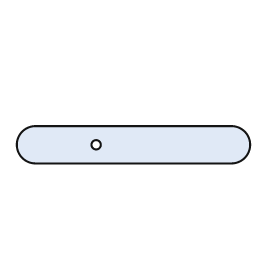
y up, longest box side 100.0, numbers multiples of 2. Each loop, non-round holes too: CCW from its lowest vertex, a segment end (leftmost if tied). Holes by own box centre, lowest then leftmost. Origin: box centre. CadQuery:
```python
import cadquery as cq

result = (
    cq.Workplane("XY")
    .moveTo(-42.0, -8.0)
    .lineTo(42.0, -8.0)
    .threePointArc((50.0, 0.0), (42.0, 8.0))
    .lineTo(-42.0, 8.0)
    .threePointArc((-50.0, 0.0), (-42.0, -8.0))
    .close()
    .moveTo(-16.0, 0.0)
    .circle(2.0)
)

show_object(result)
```